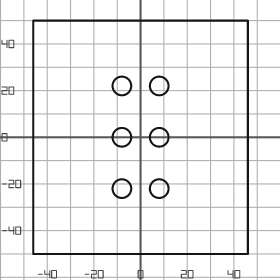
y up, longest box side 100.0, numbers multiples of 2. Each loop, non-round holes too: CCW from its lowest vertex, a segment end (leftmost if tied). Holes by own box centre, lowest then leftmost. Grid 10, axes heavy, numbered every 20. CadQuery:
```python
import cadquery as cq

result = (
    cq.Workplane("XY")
    .moveTo(-46.0, -50.0)
    .lineTo(46.0, -50.0)
    .lineTo(46.0, 50.0)
    .lineTo(-46.0, 50.0)
    .close()
    .moveTo(-8.0, -22.0)
    .circle(4.0)
    .moveTo(8.0, -22.0)
    .circle(4.0)
    .moveTo(-8.0, 0.0)
    .circle(4.0)
    .moveTo(8.0, 0.0)
    .circle(4.0)
    .moveTo(-8.0, 22.0)
    .circle(4.0)
    .moveTo(8.0, 22.0)
    .circle(4.0)
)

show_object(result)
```